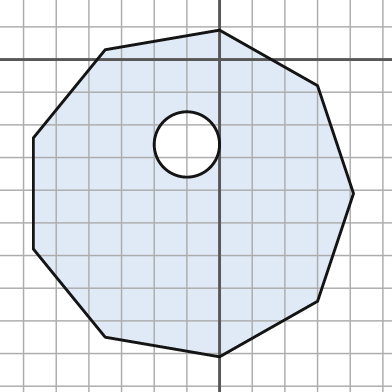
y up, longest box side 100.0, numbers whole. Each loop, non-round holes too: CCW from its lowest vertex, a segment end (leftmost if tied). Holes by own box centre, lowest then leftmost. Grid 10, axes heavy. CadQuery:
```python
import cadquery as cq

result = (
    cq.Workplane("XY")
    .moveTo(0.0, -91.0)
    .lineTo(30.0, -74.0)
    .lineTo(41.0, -41.0)
    .lineTo(30.0, -8.0)
    .lineTo(0.0, 9.0)
    .lineTo(-35.0, 3.0)
    .lineTo(-57.0, -24.0)
    .lineTo(-57.0, -58.0)
    .lineTo(-35.0, -85.0)
    .close()
    .moveTo(-10.0, -26.0)
    .circle(10.0)
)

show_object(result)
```